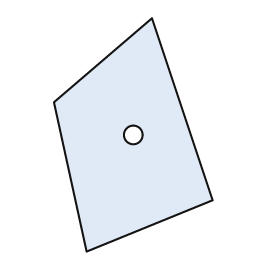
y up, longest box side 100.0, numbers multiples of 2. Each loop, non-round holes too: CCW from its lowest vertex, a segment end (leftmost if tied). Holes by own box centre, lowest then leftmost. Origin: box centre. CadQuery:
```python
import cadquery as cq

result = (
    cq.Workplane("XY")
    .moveTo(-20.0, -50.0)
    .lineTo(34.0, -28.0)
    .lineTo(8.0, 50.0)
    .lineTo(-34.0, 14.0)
    .close()
    .moveTo(0.0, 0.0)
    .circle(4.0)
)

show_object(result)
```